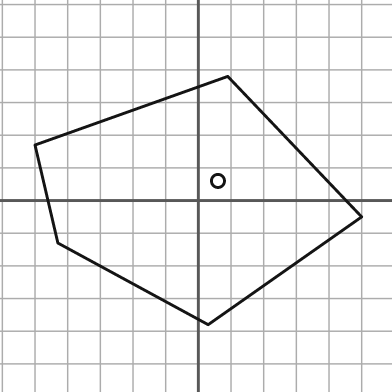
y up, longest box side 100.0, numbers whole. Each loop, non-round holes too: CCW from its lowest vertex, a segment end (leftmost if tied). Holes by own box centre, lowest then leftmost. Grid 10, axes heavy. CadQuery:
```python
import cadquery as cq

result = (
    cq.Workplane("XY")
    .moveTo(3.0, -38.0)
    .lineTo(50.0, -5.0)
    .lineTo(9.0, 38.0)
    .lineTo(-50.0, 17.0)
    .lineTo(-43.0, -13.0)
    .close()
    .moveTo(6.0, 6.0)
    .circle(2.0)
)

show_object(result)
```